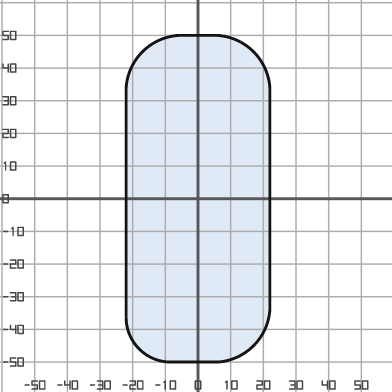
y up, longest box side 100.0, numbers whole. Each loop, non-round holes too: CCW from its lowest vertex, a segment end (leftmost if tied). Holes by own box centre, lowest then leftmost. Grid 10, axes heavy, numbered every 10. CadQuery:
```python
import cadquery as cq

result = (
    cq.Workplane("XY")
    .moveTo(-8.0, -50.0)
    .lineTo(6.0, -50.0)
    .threePointArc((17.0, -45.0), (22.0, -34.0))
    .lineTo(22.0, 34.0)
    .threePointArc((17.0, 45.0), (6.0, 50.0))
    .lineTo(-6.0, 50.0)
    .threePointArc((-17.0, 45.0), (-22.0, 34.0))
    .lineTo(-22.0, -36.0)
    .threePointArc((-18.0, -46.0), (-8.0, -50.0))
    .close()
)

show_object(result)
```